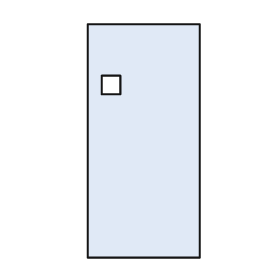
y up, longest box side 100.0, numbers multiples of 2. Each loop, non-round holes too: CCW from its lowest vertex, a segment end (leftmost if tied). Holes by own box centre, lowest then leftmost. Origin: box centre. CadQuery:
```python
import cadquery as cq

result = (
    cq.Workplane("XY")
    .moveTo(-24.0, -50.0)
    .lineTo(24.0, -50.0)
    .lineTo(24.0, 50.0)
    .lineTo(-24.0, 50.0)
    .close()
    .moveTo(-18.0, 20.0)
    .lineTo(-10.0, 20.0)
    .lineTo(-10.0, 28.0)
    .lineTo(-18.0, 28.0)
    .close()
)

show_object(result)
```